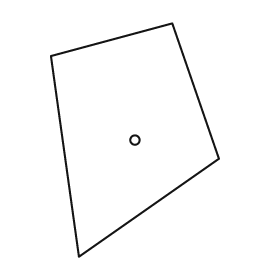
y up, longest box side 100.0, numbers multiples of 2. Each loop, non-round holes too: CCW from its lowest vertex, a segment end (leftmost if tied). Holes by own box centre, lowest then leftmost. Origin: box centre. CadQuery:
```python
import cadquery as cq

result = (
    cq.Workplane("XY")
    .moveTo(-24.0, -50.0)
    .lineTo(36.0, -8.0)
    .lineTo(16.0, 50.0)
    .lineTo(-36.0, 36.0)
    .close()
    .moveTo(0.0, 0.0)
    .circle(2.0)
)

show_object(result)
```